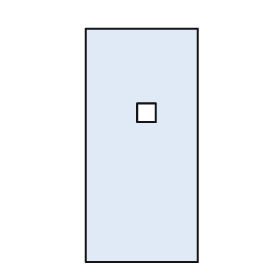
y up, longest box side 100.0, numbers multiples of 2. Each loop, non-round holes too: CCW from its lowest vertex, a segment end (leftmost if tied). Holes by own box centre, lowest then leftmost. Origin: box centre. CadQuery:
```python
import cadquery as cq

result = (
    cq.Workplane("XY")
    .moveTo(-24.0, -50.0)
    .lineTo(24.0, -50.0)
    .lineTo(24.0, 50.0)
    .lineTo(-24.0, 50.0)
    .close()
    .moveTo(-2.0, 10.0)
    .lineTo(6.0, 10.0)
    .lineTo(6.0, 18.0)
    .lineTo(-2.0, 18.0)
    .close()
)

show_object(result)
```